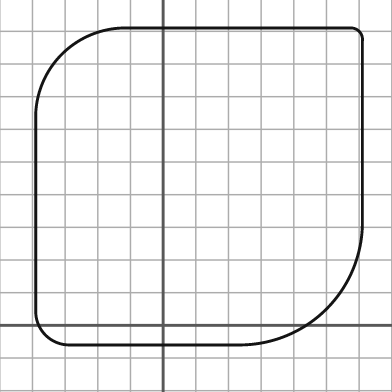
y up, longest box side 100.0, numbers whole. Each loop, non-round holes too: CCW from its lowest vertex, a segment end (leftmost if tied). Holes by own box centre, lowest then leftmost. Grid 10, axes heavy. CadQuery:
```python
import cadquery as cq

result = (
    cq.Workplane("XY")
    .moveTo(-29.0, -6.0)
    .lineTo(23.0, -6.0)
    .threePointArc((50.0, 5.0), (61.0, 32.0))
    .lineTo(61.0, 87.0)
    .threePointArc((60.0, 90.0), (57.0, 91.0))
    .lineTo(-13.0, 91.0)
    .threePointArc((-31.0, 83.0), (-39.0, 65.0))
    .lineTo(-39.0, 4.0)
    .threePointArc((-36.0, -3.0), (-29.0, -6.0))
    .close()
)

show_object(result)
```